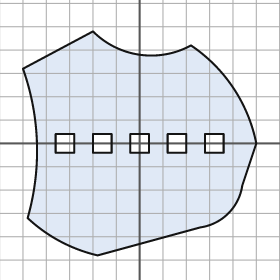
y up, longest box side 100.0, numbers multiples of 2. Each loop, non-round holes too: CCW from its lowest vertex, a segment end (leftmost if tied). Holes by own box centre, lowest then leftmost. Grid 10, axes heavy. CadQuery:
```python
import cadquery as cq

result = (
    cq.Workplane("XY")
    .moveTo(-18.0, -48.0)
    .lineTo(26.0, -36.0)
    .threePointArc((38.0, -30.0), (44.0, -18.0))
    .lineTo(50.0, 0.0)
    .threePointArc((40.0, 24.0), (22.0, 42.0))
    .threePointArc((0.0, 38.0), (-20.0, 48.0))
    .lineTo(-50.0, 32.0)
    .threePointArc((-44.0, 0.0), (-48.0, -32.0))
    .threePointArc((-34.0, -42.0), (-18.0, -48.0))
    .close()
    .moveTo(-36.0, -4.0)
    .lineTo(-28.0, -4.0)
    .lineTo(-28.0, 4.0)
    .lineTo(-36.0, 4.0)
    .close()
    .moveTo(-20.0, -4.0)
    .lineTo(-12.0, -4.0)
    .lineTo(-12.0, 4.0)
    .lineTo(-20.0, 4.0)
    .close()
    .moveTo(-4.0, -4.0)
    .lineTo(4.0, -4.0)
    .lineTo(4.0, 4.0)
    .lineTo(-4.0, 4.0)
    .close()
    .moveTo(12.0, -4.0)
    .lineTo(20.0, -4.0)
    .lineTo(20.0, 4.0)
    .lineTo(12.0, 4.0)
    .close()
    .moveTo(28.0, -4.0)
    .lineTo(36.0, -4.0)
    .lineTo(36.0, 4.0)
    .lineTo(28.0, 4.0)
    .close()
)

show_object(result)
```